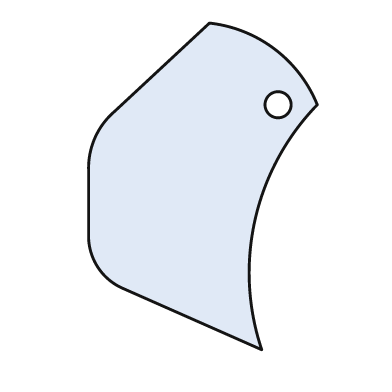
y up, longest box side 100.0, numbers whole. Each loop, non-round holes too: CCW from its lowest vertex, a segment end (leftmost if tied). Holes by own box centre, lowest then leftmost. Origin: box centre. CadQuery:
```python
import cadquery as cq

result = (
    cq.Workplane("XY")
    .moveTo(18.0, -50.0)
    .threePointArc((16.0, -10.0), (35.0, 25.0))
    .threePointArc((22.0, 42.0), (2.0, 50.0))
    .lineTo(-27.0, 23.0)
    .threePointArc((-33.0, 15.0), (-35.0, 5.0))
    .lineTo(-35.0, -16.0)
    .threePointArc((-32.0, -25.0), (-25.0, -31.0))
    .close()
    .moveTo(23.0, 25.0)
    .circle(4.0)
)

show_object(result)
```